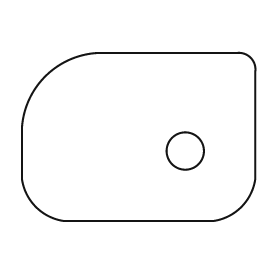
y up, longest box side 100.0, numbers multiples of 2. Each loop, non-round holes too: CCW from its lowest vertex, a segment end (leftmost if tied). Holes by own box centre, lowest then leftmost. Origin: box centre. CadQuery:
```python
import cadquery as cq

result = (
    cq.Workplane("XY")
    .moveTo(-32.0, -36.0)
    .lineTo(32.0, -36.0)
    .threePointArc((44.0, -30.0), (50.0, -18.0))
    .lineTo(50.0, 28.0)
    .threePointArc((48.0, 34.0), (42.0, 36.0))
    .lineTo(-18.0, 36.0)
    .threePointArc((-40.0, 26.0), (-50.0, 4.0))
    .lineTo(-50.0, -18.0)
    .threePointArc((-44.0, -30.0), (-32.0, -36.0))
    .close()
    .moveTo(20.0, -6.0)
    .circle(8.0)
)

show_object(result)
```